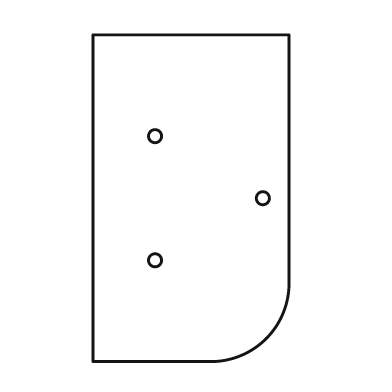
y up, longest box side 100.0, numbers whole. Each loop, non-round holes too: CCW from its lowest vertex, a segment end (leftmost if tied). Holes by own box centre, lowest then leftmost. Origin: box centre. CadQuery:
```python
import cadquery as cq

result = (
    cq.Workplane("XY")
    .moveTo(-30.0, -50.0)
    .lineTo(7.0, -50.0)
    .threePointArc((23.0, -43.0), (30.0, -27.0))
    .lineTo(30.0, 50.0)
    .lineTo(-30.0, 50.0)
    .close()
    .moveTo(-11.0, -19.0)
    .circle(2.0)
    .moveTo(22.0, 0.0)
    .circle(2.0)
    .moveTo(-11.0, 19.0)
    .circle(2.0)
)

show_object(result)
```